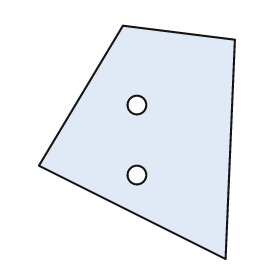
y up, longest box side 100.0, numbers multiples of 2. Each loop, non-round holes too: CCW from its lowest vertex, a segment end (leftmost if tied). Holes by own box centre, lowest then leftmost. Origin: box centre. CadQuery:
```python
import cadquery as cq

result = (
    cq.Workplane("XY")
    .moveTo(38.0, -50.0)
    .lineTo(42.0, 44.0)
    .lineTo(-6.0, 50.0)
    .lineTo(-42.0, -10.0)
    .close()
    .moveTo(0.0, -14.0)
    .circle(4.0)
    .moveTo(0.0, 16.0)
    .circle(4.0)
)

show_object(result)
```